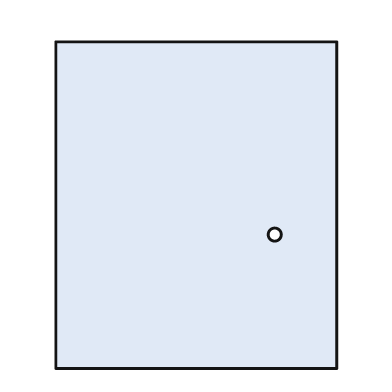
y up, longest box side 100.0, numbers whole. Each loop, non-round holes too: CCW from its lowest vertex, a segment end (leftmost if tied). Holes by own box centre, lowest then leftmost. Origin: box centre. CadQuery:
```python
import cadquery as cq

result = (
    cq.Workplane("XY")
    .moveTo(-43.0, -50.0)
    .lineTo(43.0, -50.0)
    .lineTo(43.0, 50.0)
    .lineTo(-43.0, 50.0)
    .close()
    .moveTo(24.0, -9.0)
    .circle(2.0)
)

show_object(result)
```